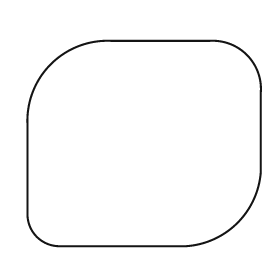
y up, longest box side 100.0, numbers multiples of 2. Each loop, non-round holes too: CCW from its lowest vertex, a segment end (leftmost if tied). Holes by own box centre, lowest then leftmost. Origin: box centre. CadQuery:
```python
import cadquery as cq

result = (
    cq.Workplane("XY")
    .moveTo(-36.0, -44.0)
    .lineTo(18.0, -44.0)
    .threePointArc((40.0, -34.0), (50.0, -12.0))
    .lineTo(50.0, 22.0)
    .threePointArc((44.0, 38.0), (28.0, 44.0))
    .lineTo(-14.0, 44.0)
    .threePointArc((-40.0, 34.0), (-50.0, 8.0))
    .lineTo(-50.0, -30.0)
    .threePointArc((-46.0, -40.0), (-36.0, -44.0))
    .close()
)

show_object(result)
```